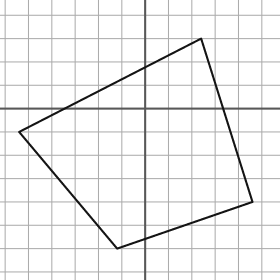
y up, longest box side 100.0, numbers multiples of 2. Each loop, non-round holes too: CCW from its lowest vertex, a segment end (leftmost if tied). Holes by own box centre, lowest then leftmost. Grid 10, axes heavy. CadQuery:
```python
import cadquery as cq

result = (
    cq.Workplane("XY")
    .moveTo(-12.0, -60.0)
    .lineTo(46.0, -40.0)
    .lineTo(24.0, 30.0)
    .lineTo(-54.0, -10.0)
    .close()
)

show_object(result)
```